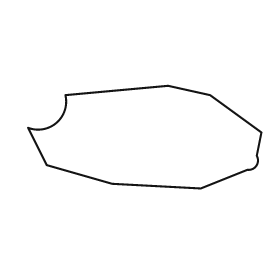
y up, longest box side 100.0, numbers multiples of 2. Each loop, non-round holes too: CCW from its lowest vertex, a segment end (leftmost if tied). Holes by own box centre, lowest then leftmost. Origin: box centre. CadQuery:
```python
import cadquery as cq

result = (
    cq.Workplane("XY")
    .moveTo(24.0, -22.0)
    .lineTo(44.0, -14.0)
    .threePointArc((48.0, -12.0), (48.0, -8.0))
    .lineTo(50.0, 2.0)
    .lineTo(28.0, 18.0)
    .lineTo(10.0, 22.0)
    .lineTo(-34.0, 18.0)
    .threePointArc((-38.0, 6.0), (-50.0, 4.0))
    .lineTo(-42.0, -12.0)
    .lineTo(-14.0, -20.0)
    .close()
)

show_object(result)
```